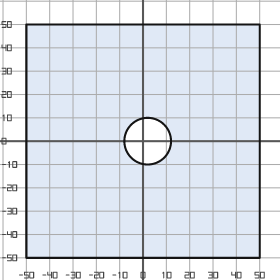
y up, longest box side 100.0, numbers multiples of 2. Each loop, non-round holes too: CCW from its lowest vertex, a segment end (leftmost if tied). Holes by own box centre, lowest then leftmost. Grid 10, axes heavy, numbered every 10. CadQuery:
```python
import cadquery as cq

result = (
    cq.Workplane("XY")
    .moveTo(-50.0, -50.0)
    .lineTo(50.0, -50.0)
    .lineTo(50.0, 50.0)
    .lineTo(-50.0, 50.0)
    .close()
    .moveTo(2.0, 0.0)
    .circle(10.0)
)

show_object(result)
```